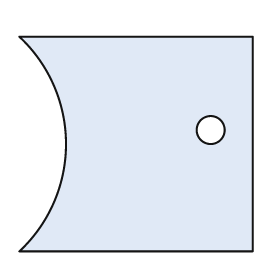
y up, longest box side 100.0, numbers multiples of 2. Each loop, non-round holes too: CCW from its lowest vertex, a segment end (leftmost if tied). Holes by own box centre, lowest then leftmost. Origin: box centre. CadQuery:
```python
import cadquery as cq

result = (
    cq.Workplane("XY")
    .moveTo(-50.0, -46.0)
    .lineTo(50.0, -46.0)
    .lineTo(50.0, 46.0)
    .lineTo(-50.0, 46.0)
    .threePointArc((-30.0, 0.0), (-50.0, -46.0))
    .close()
    .moveTo(32.0, 6.0)
    .circle(6.0)
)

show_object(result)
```